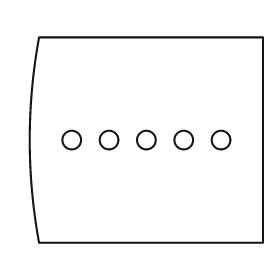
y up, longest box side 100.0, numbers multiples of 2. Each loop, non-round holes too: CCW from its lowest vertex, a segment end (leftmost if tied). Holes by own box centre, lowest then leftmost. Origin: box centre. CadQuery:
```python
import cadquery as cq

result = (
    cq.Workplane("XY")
    .moveTo(-46.0, -44.0)
    .lineTo(50.0, -44.0)
    .lineTo(50.0, 44.0)
    .lineTo(-46.0, 44.0)
    .threePointArc((-50.0, 0.0), (-46.0, -44.0))
    .close()
    .moveTo(-32.0, 0.0)
    .circle(4.0)
    .moveTo(-16.0, 0.0)
    .circle(4.0)
    .moveTo(0.0, 0.0)
    .circle(4.0)
    .moveTo(16.0, 0.0)
    .circle(4.0)
    .moveTo(32.0, 0.0)
    .circle(4.0)
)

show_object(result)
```